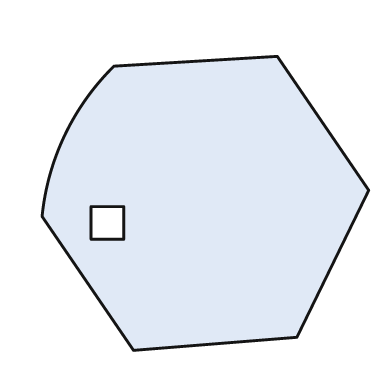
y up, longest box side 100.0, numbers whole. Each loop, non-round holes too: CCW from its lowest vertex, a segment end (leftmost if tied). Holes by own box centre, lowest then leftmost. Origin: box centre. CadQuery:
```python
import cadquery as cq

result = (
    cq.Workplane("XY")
    .moveTo(-22.0, -45.0)
    .lineTo(28.0, -41.0)
    .lineTo(50.0, 4.0)
    .lineTo(22.0, 45.0)
    .lineTo(-28.0, 42.0)
    .threePointArc((-43.0, 21.0), (-50.0, -4.0))
    .close()
    .moveTo(-35.0, -11.0)
    .lineTo(-25.0, -11.0)
    .lineTo(-25.0, -1.0)
    .lineTo(-35.0, -1.0)
    .close()
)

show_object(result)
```